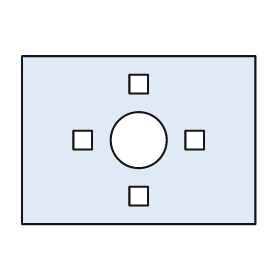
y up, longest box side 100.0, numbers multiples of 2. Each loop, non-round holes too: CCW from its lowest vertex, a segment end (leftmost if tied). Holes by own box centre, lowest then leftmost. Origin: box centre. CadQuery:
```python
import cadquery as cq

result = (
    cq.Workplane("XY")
    .moveTo(-50.0, -36.0)
    .lineTo(50.0, -36.0)
    .lineTo(50.0, 36.0)
    .lineTo(-50.0, 36.0)
    .close()
    .moveTo(-4.0, -28.0)
    .lineTo(4.0, -28.0)
    .lineTo(4.0, -20.0)
    .lineTo(-4.0, -20.0)
    .close()
    .moveTo(-28.0, -4.0)
    .lineTo(-20.0, -4.0)
    .lineTo(-20.0, 4.0)
    .lineTo(-28.0, 4.0)
    .close()
    .moveTo(0.0, 0.0)
    .circle(12.0)
    .moveTo(20.0, -4.0)
    .lineTo(28.0, -4.0)
    .lineTo(28.0, 4.0)
    .lineTo(20.0, 4.0)
    .close()
    .moveTo(-4.0, 20.0)
    .lineTo(4.0, 20.0)
    .lineTo(4.0, 28.0)
    .lineTo(-4.0, 28.0)
    .close()
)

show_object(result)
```